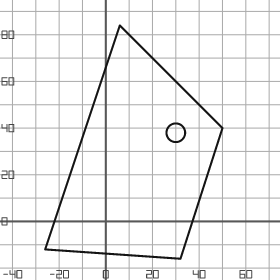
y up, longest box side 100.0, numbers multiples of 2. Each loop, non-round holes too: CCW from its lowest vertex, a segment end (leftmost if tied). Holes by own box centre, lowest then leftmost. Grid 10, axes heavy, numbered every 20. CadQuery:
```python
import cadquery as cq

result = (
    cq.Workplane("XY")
    .moveTo(32.0, -16.0)
    .lineTo(50.0, 40.0)
    .lineTo(6.0, 84.0)
    .lineTo(-26.0, -12.0)
    .close()
    .moveTo(30.0, 38.0)
    .circle(4.0)
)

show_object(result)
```